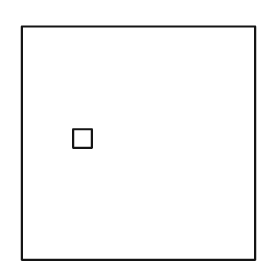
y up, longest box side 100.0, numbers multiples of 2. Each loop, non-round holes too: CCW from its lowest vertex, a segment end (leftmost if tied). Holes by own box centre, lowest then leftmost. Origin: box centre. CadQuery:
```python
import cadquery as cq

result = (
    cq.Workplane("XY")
    .moveTo(-50.0, -50.0)
    .lineTo(50.0, -50.0)
    .lineTo(50.0, 50.0)
    .lineTo(-50.0, 50.0)
    .close()
    .moveTo(-28.0, -2.0)
    .lineTo(-20.0, -2.0)
    .lineTo(-20.0, 6.0)
    .lineTo(-28.0, 6.0)
    .close()
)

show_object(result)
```